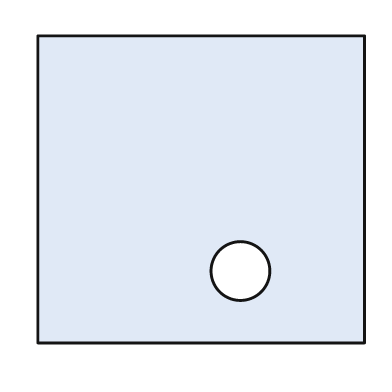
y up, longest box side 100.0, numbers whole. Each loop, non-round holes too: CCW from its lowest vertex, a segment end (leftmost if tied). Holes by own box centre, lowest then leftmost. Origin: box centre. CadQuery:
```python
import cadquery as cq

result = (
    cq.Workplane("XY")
    .moveTo(-50.0, -47.0)
    .lineTo(50.0, -47.0)
    .lineTo(50.0, 47.0)
    .lineTo(-50.0, 47.0)
    .close()
    .moveTo(12.0, -25.0)
    .circle(9.0)
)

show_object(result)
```